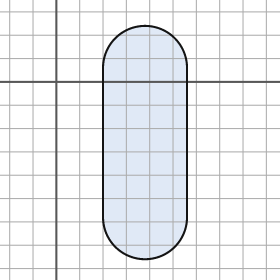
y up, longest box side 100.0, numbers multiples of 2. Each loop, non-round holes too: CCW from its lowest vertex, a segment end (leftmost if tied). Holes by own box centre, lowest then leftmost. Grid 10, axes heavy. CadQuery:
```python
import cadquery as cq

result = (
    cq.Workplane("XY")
    .moveTo(20.0, -58.0)
    .threePointArc((38.0, -76.0), (56.0, -58.0))
    .lineTo(56.0, 6.0)
    .threePointArc((38.0, 24.0), (20.0, 6.0))
    .close()
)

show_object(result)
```